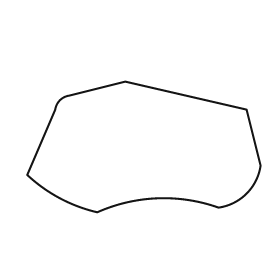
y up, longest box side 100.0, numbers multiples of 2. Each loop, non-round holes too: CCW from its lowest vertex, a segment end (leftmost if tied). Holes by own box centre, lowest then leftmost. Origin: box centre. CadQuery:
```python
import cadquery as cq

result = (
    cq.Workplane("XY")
    .moveTo(-20.0, -28.0)
    .threePointArc((6.0, -22.0), (32.0, -26.0))
    .threePointArc((44.0, -20.0), (50.0, -8.0))
    .lineTo(44.0, 16.0)
    .lineTo(-8.0, 28.0)
    .lineTo(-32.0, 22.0)
    .threePointArc((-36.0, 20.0), (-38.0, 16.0))
    .lineTo(-50.0, -12.0)
    .threePointArc((-36.0, -22.0), (-20.0, -28.0))
    .close()
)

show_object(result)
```